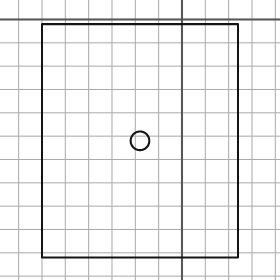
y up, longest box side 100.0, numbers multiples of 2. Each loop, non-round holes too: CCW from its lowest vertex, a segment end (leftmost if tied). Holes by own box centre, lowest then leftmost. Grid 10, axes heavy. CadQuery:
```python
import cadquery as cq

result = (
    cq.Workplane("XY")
    .moveTo(-60.0, -102.0)
    .lineTo(24.0, -102.0)
    .lineTo(24.0, -2.0)
    .lineTo(-60.0, -2.0)
    .close()
    .moveTo(-18.0, -52.0)
    .circle(4.0)
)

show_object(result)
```